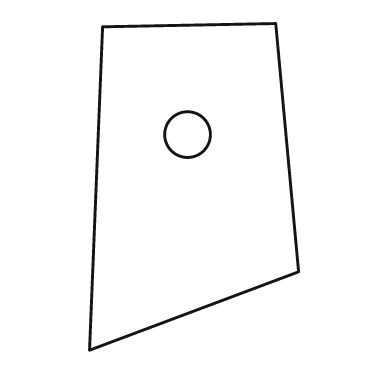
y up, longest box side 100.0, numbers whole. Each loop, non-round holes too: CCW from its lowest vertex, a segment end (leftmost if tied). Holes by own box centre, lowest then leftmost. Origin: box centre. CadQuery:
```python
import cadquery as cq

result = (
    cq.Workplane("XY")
    .moveTo(-32.0, -50.0)
    .lineTo(32.0, -26.0)
    .lineTo(25.0, 50.0)
    .lineTo(-28.0, 49.0)
    .close()
    .moveTo(-2.0, 16.0)
    .circle(7.0)
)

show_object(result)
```